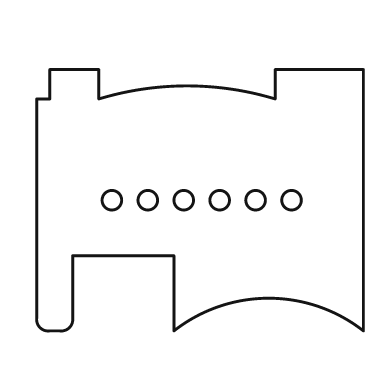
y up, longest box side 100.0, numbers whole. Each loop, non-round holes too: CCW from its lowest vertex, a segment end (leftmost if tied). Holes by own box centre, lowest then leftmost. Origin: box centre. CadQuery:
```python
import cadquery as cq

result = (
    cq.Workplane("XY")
    .moveTo(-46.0, -40.0)
    .lineTo(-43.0, -40.0)
    .threePointArc((-40.0, -39.0), (-39.0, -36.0))
    .lineTo(-39.0, -17.0)
    .lineTo(-8.0, -17.0)
    .lineTo(-8.0, -40.0)
    .threePointArc((21.0, -30.0), (50.0, -40.0))
    .lineTo(50.0, 40.0)
    .lineTo(23.0, 40.0)
    .lineTo(23.0, 31.0)
    .threePointArc((-4.0, 35.0), (-31.0, 31.0))
    .lineTo(-31.0, 40.0)
    .lineTo(-46.0, 40.0)
    .lineTo(-46.0, 31.0)
    .lineTo(-50.0, 31.0)
    .lineTo(-50.0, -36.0)
    .threePointArc((-49.0, -39.0), (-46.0, -40.0))
    .close()
    .moveTo(-27.0, 0.0)
    .circle(3.0)
    .moveTo(-16.0, 0.0)
    .circle(3.0)
    .moveTo(-5.0, 0.0)
    .circle(3.0)
    .moveTo(6.0, 0.0)
    .circle(3.0)
    .moveTo(17.0, 0.0)
    .circle(3.0)
    .moveTo(28.0, 0.0)
    .circle(3.0)
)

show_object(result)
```